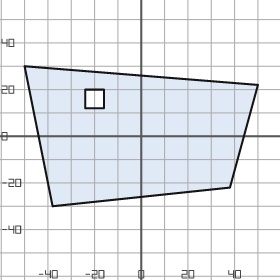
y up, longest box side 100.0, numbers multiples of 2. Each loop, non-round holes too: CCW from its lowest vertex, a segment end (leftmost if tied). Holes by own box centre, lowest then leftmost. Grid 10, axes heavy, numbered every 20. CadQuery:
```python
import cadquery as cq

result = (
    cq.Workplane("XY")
    .moveTo(-38.0, -30.0)
    .lineTo(38.0, -22.0)
    .lineTo(50.0, 22.0)
    .lineTo(-50.0, 30.0)
    .close()
    .moveTo(-24.0, 12.0)
    .lineTo(-16.0, 12.0)
    .lineTo(-16.0, 20.0)
    .lineTo(-24.0, 20.0)
    .close()
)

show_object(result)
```